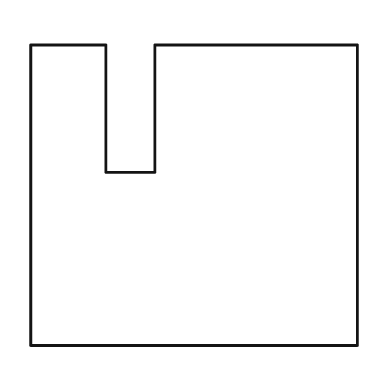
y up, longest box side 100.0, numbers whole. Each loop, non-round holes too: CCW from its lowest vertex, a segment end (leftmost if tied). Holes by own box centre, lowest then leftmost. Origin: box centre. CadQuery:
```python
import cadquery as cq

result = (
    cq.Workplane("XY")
    .moveTo(-50.0, -46.0)
    .lineTo(50.0, -46.0)
    .lineTo(50.0, 46.0)
    .lineTo(-12.0, 46.0)
    .lineTo(-12.0, 7.0)
    .lineTo(-27.0, 7.0)
    .lineTo(-27.0, 46.0)
    .lineTo(-50.0, 46.0)
    .close()
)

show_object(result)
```